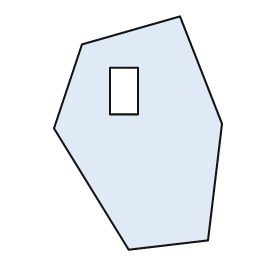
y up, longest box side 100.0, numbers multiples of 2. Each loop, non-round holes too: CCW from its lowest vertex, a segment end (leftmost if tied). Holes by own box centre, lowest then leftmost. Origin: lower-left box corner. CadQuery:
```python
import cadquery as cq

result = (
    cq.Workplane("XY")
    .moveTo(32.0, 0.0)
    .lineTo(66.0, 4.0)
    .lineTo(72.0, 54.0)
    .lineTo(54.0, 100.0)
    .lineTo(12.0, 88.0)
    .lineTo(0.0, 52.0)
    .close()
    .moveTo(24.0, 58.0)
    .lineTo(36.0, 58.0)
    .lineTo(36.0, 78.0)
    .lineTo(24.0, 78.0)
    .close()
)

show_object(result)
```